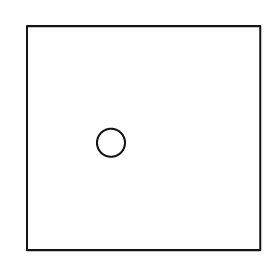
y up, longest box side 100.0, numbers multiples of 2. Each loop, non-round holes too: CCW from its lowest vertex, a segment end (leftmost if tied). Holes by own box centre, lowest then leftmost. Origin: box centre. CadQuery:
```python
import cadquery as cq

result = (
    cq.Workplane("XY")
    .moveTo(-50.0, -48.0)
    .lineTo(50.0, -48.0)
    .lineTo(50.0, 48.0)
    .lineTo(-50.0, 48.0)
    .close()
    .moveTo(-14.0, -2.0)
    .circle(6.0)
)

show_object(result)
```